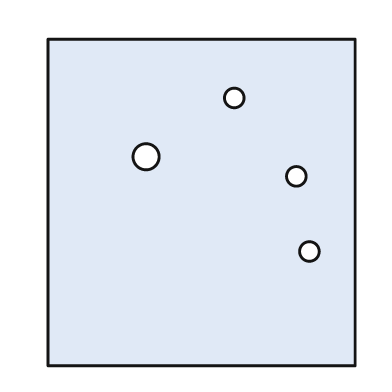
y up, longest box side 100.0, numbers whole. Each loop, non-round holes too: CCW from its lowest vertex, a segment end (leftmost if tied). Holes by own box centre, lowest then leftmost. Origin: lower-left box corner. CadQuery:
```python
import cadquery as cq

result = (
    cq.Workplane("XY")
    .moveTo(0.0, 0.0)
    .lineTo(94.0, 0.0)
    .lineTo(94.0, 100.0)
    .lineTo(0.0, 100.0)
    .close()
    .moveTo(80.0, 35.0)
    .circle(3.0)
    .moveTo(76.0, 58.0)
    .circle(3.0)
    .moveTo(30.0, 64.0)
    .circle(4.0)
    .moveTo(57.0, 82.0)
    .circle(3.0)
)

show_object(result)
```